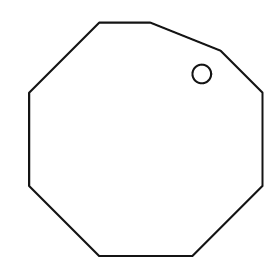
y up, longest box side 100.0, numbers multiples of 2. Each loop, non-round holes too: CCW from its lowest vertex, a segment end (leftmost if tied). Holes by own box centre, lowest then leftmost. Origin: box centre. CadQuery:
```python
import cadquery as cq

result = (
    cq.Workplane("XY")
    .moveTo(-20.0, -50.0)
    .lineTo(20.0, -50.0)
    .lineTo(50.0, -20.0)
    .lineTo(50.0, 20.0)
    .lineTo(32.0, 38.0)
    .lineTo(2.0, 50.0)
    .lineTo(-20.0, 50.0)
    .lineTo(-50.0, 20.0)
    .lineTo(-50.0, -20.0)
    .close()
    .moveTo(24.0, 28.0)
    .circle(4.0)
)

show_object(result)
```